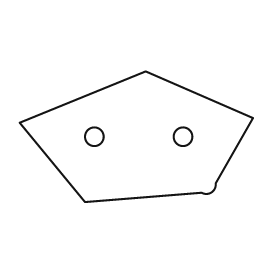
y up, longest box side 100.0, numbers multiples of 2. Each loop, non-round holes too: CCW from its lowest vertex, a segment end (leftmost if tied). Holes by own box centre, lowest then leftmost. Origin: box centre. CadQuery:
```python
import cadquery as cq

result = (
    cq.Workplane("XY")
    .moveTo(-22.0, -28.0)
    .lineTo(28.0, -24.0)
    .threePointArc((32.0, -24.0), (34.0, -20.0))
    .lineTo(50.0, 8.0)
    .lineTo(4.0, 28.0)
    .lineTo(-50.0, 6.0)
    .close()
    .moveTo(-18.0, 0.0)
    .circle(4.0)
    .moveTo(20.0, 0.0)
    .circle(4.0)
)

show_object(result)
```